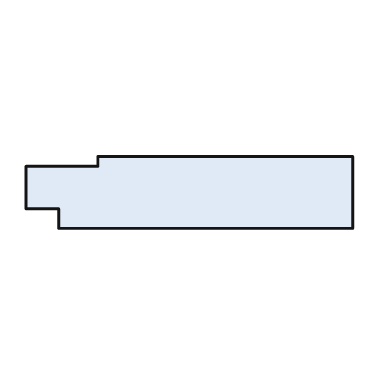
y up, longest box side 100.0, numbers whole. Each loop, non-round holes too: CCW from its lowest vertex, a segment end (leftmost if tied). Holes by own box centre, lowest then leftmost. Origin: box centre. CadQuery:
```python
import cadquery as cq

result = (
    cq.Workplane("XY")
    .moveTo(-40.0, -11.0)
    .lineTo(50.0, -11.0)
    .lineTo(50.0, 11.0)
    .lineTo(-28.0, 11.0)
    .lineTo(-28.0, 8.0)
    .lineTo(-50.0, 8.0)
    .lineTo(-50.0, -5.0)
    .lineTo(-40.0, -5.0)
    .close()
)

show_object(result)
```